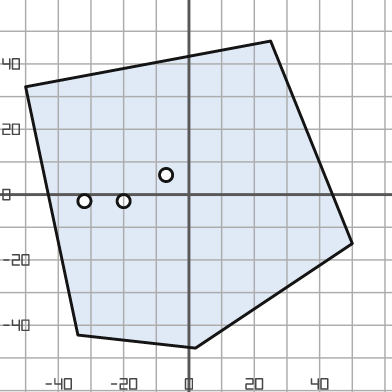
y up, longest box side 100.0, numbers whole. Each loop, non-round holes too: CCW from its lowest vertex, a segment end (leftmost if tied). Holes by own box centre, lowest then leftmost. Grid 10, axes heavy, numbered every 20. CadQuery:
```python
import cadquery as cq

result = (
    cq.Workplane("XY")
    .moveTo(2.0, -47.0)
    .lineTo(50.0, -15.0)
    .lineTo(25.0, 47.0)
    .lineTo(-50.0, 33.0)
    .lineTo(-34.0, -43.0)
    .close()
    .moveTo(-32.0, -2.0)
    .circle(2.0)
    .moveTo(-20.0, -2.0)
    .circle(2.0)
    .moveTo(-7.0, 6.0)
    .circle(2.0)
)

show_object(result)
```